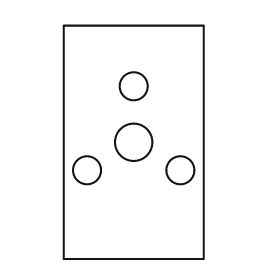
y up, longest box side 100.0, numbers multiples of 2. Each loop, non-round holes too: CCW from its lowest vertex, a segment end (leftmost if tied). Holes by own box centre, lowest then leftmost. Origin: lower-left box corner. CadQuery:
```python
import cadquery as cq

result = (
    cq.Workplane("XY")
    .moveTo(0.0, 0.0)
    .lineTo(60.0, 0.0)
    .lineTo(60.0, 100.0)
    .lineTo(0.0, 100.0)
    .close()
    .moveTo(10.0, 38.0)
    .circle(6.0)
    .moveTo(50.0, 38.0)
    .circle(6.0)
    .moveTo(30.0, 50.0)
    .circle(8.0)
    .moveTo(30.0, 74.0)
    .circle(6.0)
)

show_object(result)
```